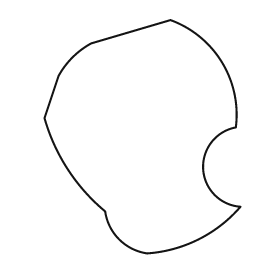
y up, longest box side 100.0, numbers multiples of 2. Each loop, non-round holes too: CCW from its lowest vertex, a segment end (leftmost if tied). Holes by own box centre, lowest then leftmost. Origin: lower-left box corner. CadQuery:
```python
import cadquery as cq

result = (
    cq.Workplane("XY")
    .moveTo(44.0, 0.0)
    .threePointArc((66.0, 6.0), (84.0, 20.0))
    .threePointArc((68.0, 36.0), (82.0, 54.0))
    .threePointArc((76.0, 82.0), (54.0, 100.0))
    .lineTo(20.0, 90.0)
    .threePointArc((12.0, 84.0), (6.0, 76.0))
    .lineTo(0.0, 58.0)
    .threePointArc((10.0, 36.0), (26.0, 18.0))
    .threePointArc((32.0, 6.0), (44.0, 0.0))
    .close()
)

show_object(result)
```